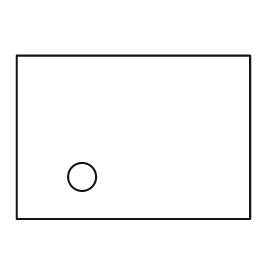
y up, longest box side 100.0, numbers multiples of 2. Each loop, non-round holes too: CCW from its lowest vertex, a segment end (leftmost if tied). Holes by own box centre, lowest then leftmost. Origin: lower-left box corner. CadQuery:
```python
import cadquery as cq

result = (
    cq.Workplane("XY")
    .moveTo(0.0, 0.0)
    .lineTo(100.0, 0.0)
    .lineTo(100.0, 70.0)
    .lineTo(0.0, 70.0)
    .close()
    .moveTo(28.0, 18.0)
    .circle(6.0)
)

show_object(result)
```